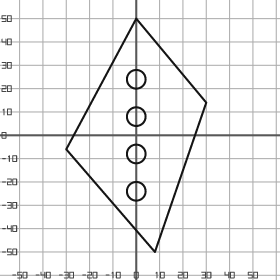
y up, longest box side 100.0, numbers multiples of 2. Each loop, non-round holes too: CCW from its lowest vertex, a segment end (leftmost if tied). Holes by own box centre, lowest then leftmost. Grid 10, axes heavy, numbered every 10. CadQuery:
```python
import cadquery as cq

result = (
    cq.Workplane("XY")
    .moveTo(8.0, -50.0)
    .lineTo(30.0, 14.0)
    .lineTo(0.0, 50.0)
    .lineTo(-30.0, -6.0)
    .close()
    .moveTo(0.0, -24.0)
    .circle(4.0)
    .moveTo(0.0, -8.0)
    .circle(4.0)
    .moveTo(0.0, 8.0)
    .circle(4.0)
    .moveTo(0.0, 24.0)
    .circle(4.0)
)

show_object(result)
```